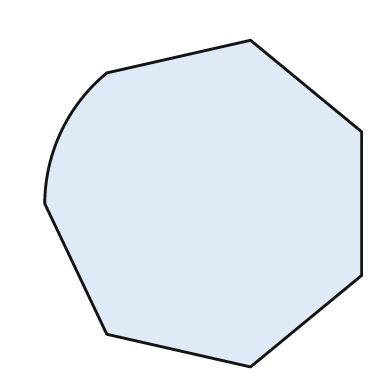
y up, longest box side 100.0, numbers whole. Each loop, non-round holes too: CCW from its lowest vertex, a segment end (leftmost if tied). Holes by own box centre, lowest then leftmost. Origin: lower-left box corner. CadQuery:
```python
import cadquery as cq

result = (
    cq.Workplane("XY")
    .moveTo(63.0, 0.0)
    .lineTo(97.0, 28.0)
    .lineTo(97.0, 72.0)
    .lineTo(63.0, 100.0)
    .lineTo(19.0, 90.0)
    .threePointArc((5.0, 72.0), (0.0, 50.0))
    .lineTo(19.0, 10.0)
    .close()
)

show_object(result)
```